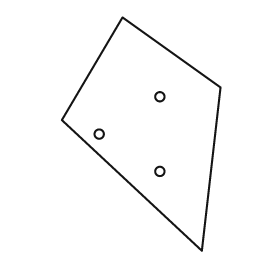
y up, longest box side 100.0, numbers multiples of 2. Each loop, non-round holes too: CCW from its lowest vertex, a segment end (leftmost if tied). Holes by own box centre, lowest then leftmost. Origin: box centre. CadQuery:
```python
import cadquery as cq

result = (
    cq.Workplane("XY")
    .moveTo(26.0, -50.0)
    .lineTo(34.0, 20.0)
    .lineTo(-8.0, 50.0)
    .lineTo(-34.0, 6.0)
    .close()
    .moveTo(8.0, -16.0)
    .circle(2.0)
    .moveTo(-18.0, 0.0)
    .circle(2.0)
    .moveTo(8.0, 16.0)
    .circle(2.0)
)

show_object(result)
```